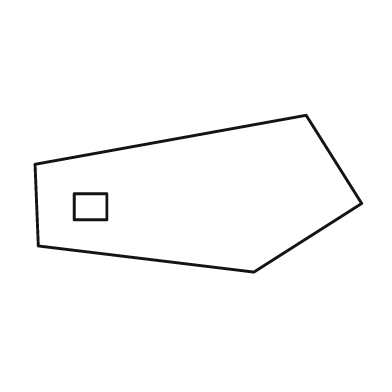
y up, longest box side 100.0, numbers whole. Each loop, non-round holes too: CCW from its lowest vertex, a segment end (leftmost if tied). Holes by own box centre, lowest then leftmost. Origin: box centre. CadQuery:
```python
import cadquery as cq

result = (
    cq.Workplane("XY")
    .moveTo(17.0, -24.0)
    .lineTo(50.0, -3.0)
    .lineTo(33.0, 24.0)
    .lineTo(-50.0, 9.0)
    .lineTo(-49.0, -16.0)
    .close()
    .moveTo(-38.0, -8.0)
    .lineTo(-28.0, -8.0)
    .lineTo(-28.0, 0.0)
    .lineTo(-38.0, 0.0)
    .close()
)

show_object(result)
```